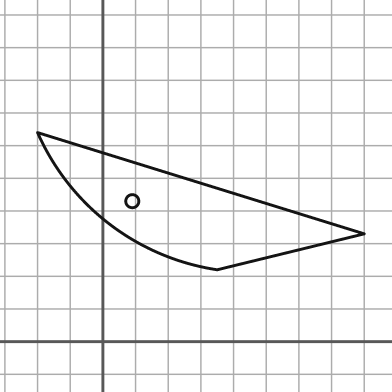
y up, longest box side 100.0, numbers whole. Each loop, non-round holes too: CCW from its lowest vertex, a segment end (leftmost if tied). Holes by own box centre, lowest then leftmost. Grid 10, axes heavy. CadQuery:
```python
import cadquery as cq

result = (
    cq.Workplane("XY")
    .moveTo(35.0, 22.0)
    .lineTo(80.0, 33.0)
    .lineTo(-20.0, 64.0)
    .threePointArc((2.0, 36.0), (35.0, 22.0))
    .close()
    .moveTo(9.0, 43.0)
    .circle(2.0)
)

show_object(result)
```